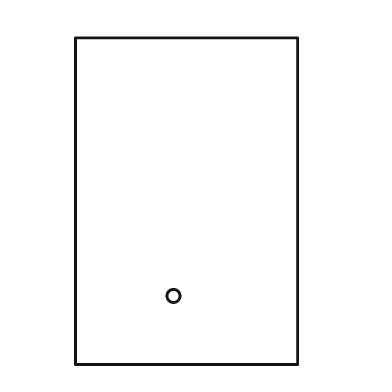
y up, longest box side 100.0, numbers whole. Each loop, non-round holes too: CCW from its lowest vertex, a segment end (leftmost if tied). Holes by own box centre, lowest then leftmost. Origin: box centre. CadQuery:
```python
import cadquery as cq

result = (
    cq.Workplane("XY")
    .moveTo(-34.0, -50.0)
    .lineTo(34.0, -50.0)
    .lineTo(34.0, 50.0)
    .lineTo(-34.0, 50.0)
    .close()
    .moveTo(-4.0, -29.0)
    .circle(2.0)
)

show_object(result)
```